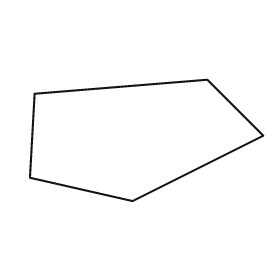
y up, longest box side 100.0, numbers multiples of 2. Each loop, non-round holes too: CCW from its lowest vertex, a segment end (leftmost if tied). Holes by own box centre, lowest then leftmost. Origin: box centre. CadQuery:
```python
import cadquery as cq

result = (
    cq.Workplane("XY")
    .moveTo(-6.0, -26.0)
    .lineTo(50.0, 2.0)
    .lineTo(26.0, 26.0)
    .lineTo(-48.0, 20.0)
    .lineTo(-50.0, -16.0)
    .close()
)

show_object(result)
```